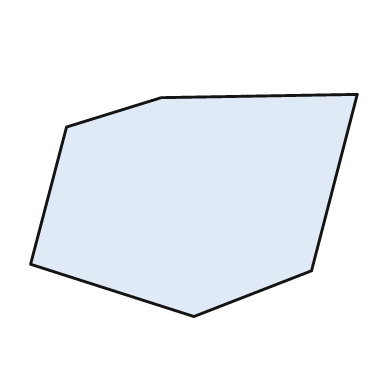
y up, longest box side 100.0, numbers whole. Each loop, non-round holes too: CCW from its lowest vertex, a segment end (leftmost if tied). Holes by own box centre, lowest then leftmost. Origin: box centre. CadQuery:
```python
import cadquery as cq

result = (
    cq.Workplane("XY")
    .moveTo(0.0, -34.0)
    .lineTo(36.0, -20.0)
    .lineTo(50.0, 34.0)
    .lineTo(-10.0, 33.0)
    .lineTo(-39.0, 24.0)
    .lineTo(-50.0, -18.0)
    .close()
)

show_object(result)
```